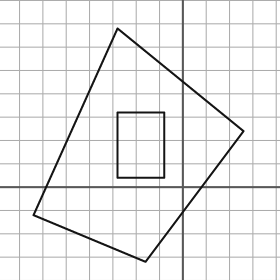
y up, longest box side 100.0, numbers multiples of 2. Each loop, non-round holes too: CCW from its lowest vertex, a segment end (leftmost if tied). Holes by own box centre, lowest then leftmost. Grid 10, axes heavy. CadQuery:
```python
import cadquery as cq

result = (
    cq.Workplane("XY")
    .moveTo(-16.0, -32.0)
    .lineTo(26.0, 24.0)
    .lineTo(-28.0, 68.0)
    .lineTo(-64.0, -12.0)
    .close()
    .moveTo(-28.0, 4.0)
    .lineTo(-8.0, 4.0)
    .lineTo(-8.0, 32.0)
    .lineTo(-28.0, 32.0)
    .close()
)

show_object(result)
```